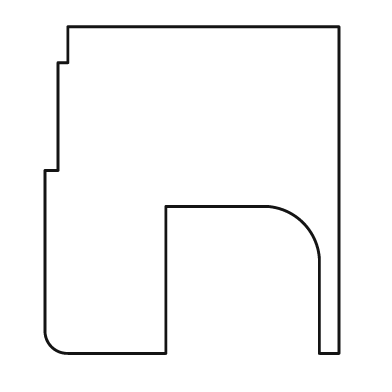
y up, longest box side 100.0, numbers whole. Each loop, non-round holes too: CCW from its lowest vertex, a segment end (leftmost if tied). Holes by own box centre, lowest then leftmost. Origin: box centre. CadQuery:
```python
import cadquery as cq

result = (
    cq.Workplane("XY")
    .moveTo(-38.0, -50.0)
    .lineTo(-8.0, -50.0)
    .lineTo(-8.0, -5.0)
    .lineTo(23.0, -5.0)
    .threePointArc((34.0, -10.0), (39.0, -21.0))
    .lineTo(39.0, -50.0)
    .lineTo(45.0, -50.0)
    .lineTo(45.0, 50.0)
    .lineTo(-38.0, 50.0)
    .lineTo(-38.0, 39.0)
    .lineTo(-41.0, 39.0)
    .lineTo(-41.0, 6.0)
    .lineTo(-45.0, 6.0)
    .lineTo(-45.0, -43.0)
    .threePointArc((-43.0, -48.0), (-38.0, -50.0))
    .close()
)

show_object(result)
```